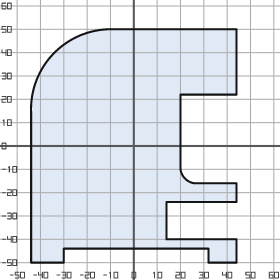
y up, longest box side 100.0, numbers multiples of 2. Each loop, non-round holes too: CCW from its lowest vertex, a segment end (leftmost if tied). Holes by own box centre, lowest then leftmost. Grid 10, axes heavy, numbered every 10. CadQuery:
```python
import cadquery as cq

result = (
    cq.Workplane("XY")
    .moveTo(-44.0, -50.0)
    .lineTo(-30.0, -50.0)
    .lineTo(-30.0, -44.0)
    .lineTo(32.0, -44.0)
    .lineTo(32.0, -50.0)
    .lineTo(44.0, -50.0)
    .lineTo(44.0, -40.0)
    .lineTo(14.0, -40.0)
    .lineTo(14.0, -24.0)
    .lineTo(44.0, -24.0)
    .lineTo(44.0, -16.0)
    .lineTo(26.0, -16.0)
    .threePointArc((22.0, -14.0), (20.0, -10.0))
    .lineTo(20.0, 22.0)
    .lineTo(44.0, 22.0)
    .lineTo(44.0, 50.0)
    .lineTo(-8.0, 50.0)
    .threePointArc((-34.0, 40.0), (-44.0, 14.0))
    .close()
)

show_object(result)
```